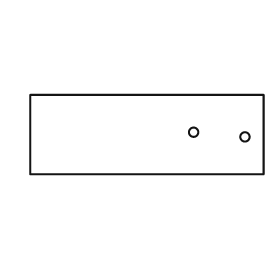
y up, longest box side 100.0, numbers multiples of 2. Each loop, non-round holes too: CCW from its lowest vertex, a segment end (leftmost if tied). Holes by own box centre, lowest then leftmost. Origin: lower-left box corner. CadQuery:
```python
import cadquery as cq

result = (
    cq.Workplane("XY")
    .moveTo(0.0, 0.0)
    .lineTo(100.0, 0.0)
    .lineTo(100.0, 34.0)
    .lineTo(0.0, 34.0)
    .close()
    .moveTo(92.0, 16.0)
    .circle(2.0)
    .moveTo(70.0, 18.0)
    .circle(2.0)
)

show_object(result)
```